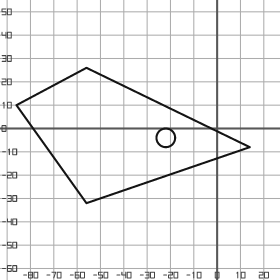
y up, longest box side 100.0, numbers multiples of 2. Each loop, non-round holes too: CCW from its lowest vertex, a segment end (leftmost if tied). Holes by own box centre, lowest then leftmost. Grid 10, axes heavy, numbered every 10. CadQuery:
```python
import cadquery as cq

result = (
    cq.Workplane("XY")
    .moveTo(-56.0, -32.0)
    .lineTo(14.0, -8.0)
    .lineTo(-56.0, 26.0)
    .lineTo(-86.0, 10.0)
    .close()
    .moveTo(-22.0, -4.0)
    .circle(4.0)
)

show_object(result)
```